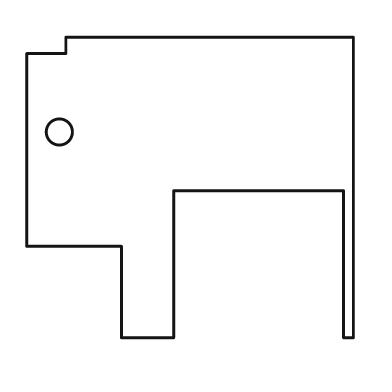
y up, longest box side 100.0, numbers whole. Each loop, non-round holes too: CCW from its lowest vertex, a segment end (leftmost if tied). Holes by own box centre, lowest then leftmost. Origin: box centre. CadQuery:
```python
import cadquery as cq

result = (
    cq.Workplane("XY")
    .moveTo(-21.0, -46.0)
    .lineTo(-5.0, -46.0)
    .lineTo(-5.0, -1.0)
    .lineTo(47.0, -1.0)
    .lineTo(47.0, -46.0)
    .lineTo(50.0, -46.0)
    .lineTo(50.0, 46.0)
    .lineTo(-38.0, 46.0)
    .lineTo(-38.0, 41.0)
    .lineTo(-50.0, 41.0)
    .lineTo(-50.0, -18.0)
    .lineTo(-21.0, -18.0)
    .close()
    .moveTo(-40.0, 17.0)
    .circle(4.0)
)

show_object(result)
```